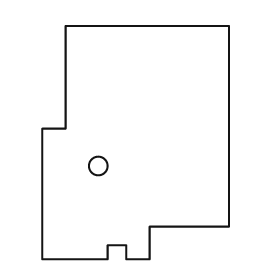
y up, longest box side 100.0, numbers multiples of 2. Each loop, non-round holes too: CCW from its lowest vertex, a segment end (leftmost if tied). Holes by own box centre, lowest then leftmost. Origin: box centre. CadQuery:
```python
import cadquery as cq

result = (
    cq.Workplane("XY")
    .moveTo(-40.0, -50.0)
    .lineTo(-12.0, -50.0)
    .lineTo(-12.0, -44.0)
    .lineTo(-4.0, -44.0)
    .lineTo(-4.0, -50.0)
    .lineTo(6.0, -50.0)
    .lineTo(6.0, -36.0)
    .lineTo(40.0, -36.0)
    .lineTo(40.0, 50.0)
    .lineTo(-30.0, 50.0)
    .lineTo(-30.0, 6.0)
    .lineTo(-40.0, 6.0)
    .close()
    .moveTo(-16.0, -10.0)
    .circle(4.0)
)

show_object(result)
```